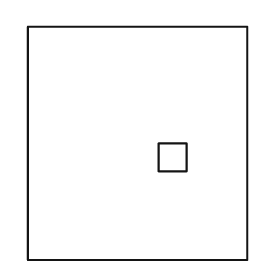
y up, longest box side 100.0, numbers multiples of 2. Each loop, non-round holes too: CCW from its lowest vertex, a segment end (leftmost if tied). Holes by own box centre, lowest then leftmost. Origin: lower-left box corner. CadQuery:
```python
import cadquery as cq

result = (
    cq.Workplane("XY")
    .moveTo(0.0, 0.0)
    .lineTo(94.0, 0.0)
    .lineTo(94.0, 100.0)
    .lineTo(0.0, 100.0)
    .close()
    .moveTo(56.0, 38.0)
    .lineTo(68.0, 38.0)
    .lineTo(68.0, 50.0)
    .lineTo(56.0, 50.0)
    .close()
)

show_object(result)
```